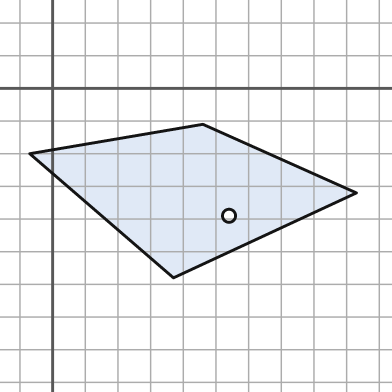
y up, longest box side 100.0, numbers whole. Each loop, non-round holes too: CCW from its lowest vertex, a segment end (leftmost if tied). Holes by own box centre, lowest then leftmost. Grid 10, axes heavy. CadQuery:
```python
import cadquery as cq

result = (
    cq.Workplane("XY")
    .moveTo(37.0, -58.0)
    .lineTo(93.0, -32.0)
    .lineTo(46.0, -11.0)
    .lineTo(-7.0, -20.0)
    .close()
    .moveTo(54.0, -39.0)
    .circle(2.0)
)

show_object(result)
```